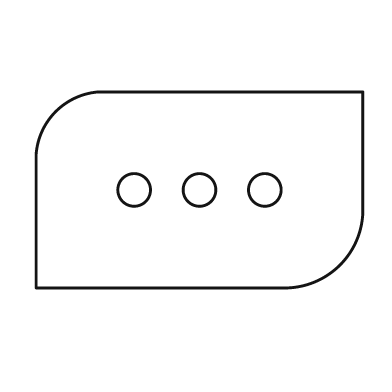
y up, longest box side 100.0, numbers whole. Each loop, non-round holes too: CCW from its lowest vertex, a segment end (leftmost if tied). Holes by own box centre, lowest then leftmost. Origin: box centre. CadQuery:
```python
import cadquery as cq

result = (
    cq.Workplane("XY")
    .moveTo(-50.0, -30.0)
    .lineTo(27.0, -30.0)
    .threePointArc((43.0, -23.0), (50.0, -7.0))
    .lineTo(50.0, 30.0)
    .lineTo(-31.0, 30.0)
    .threePointArc((-44.0, 24.0), (-50.0, 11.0))
    .close()
    .moveTo(-20.0, 0.0)
    .circle(5.0)
    .moveTo(0.0, 0.0)
    .circle(5.0)
    .moveTo(20.0, 0.0)
    .circle(5.0)
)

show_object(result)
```